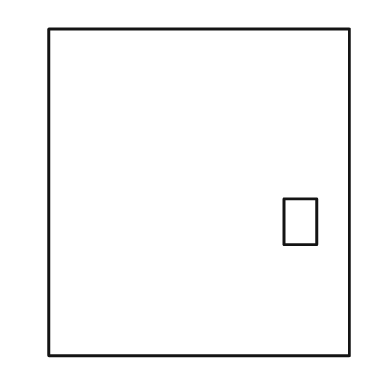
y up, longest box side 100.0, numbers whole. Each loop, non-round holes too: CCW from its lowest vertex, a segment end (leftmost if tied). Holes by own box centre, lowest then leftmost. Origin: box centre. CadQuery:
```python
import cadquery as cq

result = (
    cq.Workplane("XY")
    .moveTo(-46.0, -50.0)
    .lineTo(46.0, -50.0)
    .lineTo(46.0, 50.0)
    .lineTo(-46.0, 50.0)
    .close()
    .moveTo(26.0, -16.0)
    .lineTo(36.0, -16.0)
    .lineTo(36.0, -2.0)
    .lineTo(26.0, -2.0)
    .close()
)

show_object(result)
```